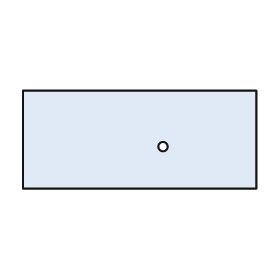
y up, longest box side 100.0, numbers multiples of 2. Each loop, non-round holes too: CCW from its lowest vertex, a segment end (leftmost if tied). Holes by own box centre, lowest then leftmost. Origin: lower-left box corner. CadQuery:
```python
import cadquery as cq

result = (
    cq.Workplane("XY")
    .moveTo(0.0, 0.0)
    .lineTo(100.0, 0.0)
    .lineTo(100.0, 42.0)
    .lineTo(0.0, 42.0)
    .close()
    .moveTo(60.0, 18.0)
    .circle(2.0)
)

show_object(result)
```